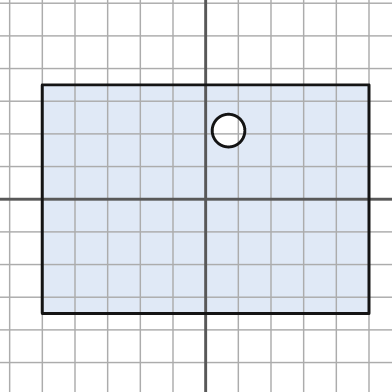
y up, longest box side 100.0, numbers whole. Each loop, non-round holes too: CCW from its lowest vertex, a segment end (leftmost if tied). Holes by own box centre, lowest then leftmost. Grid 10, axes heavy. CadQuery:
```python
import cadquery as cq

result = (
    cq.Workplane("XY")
    .moveTo(-50.0, -35.0)
    .lineTo(50.0, -35.0)
    .lineTo(50.0, 35.0)
    .lineTo(-50.0, 35.0)
    .close()
    .moveTo(7.0, 21.0)
    .circle(5.0)
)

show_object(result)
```